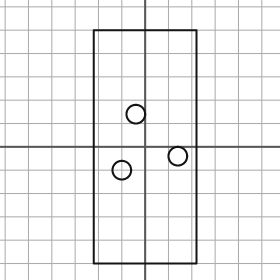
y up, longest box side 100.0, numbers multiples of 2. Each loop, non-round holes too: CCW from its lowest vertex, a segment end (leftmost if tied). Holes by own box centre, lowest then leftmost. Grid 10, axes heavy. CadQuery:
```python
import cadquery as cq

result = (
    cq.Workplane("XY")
    .moveTo(-22.0, -50.0)
    .lineTo(22.0, -50.0)
    .lineTo(22.0, 50.0)
    .lineTo(-22.0, 50.0)
    .close()
    .moveTo(-10.0, -10.0)
    .circle(4.0)
    .moveTo(14.0, -4.0)
    .circle(4.0)
    .moveTo(-4.0, 14.0)
    .circle(4.0)
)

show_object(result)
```